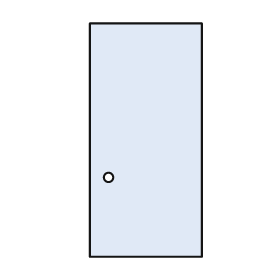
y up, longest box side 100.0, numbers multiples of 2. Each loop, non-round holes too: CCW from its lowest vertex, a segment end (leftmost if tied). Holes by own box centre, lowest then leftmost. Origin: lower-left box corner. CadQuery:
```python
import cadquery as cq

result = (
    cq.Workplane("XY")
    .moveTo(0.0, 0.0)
    .lineTo(48.0, 0.0)
    .lineTo(48.0, 100.0)
    .lineTo(0.0, 100.0)
    .close()
    .moveTo(8.0, 34.0)
    .circle(2.0)
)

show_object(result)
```